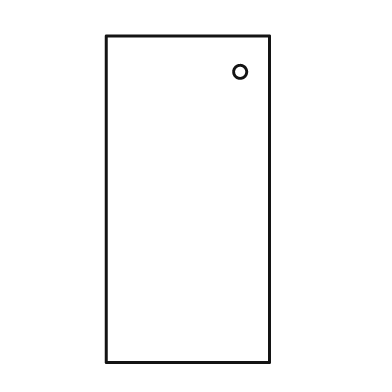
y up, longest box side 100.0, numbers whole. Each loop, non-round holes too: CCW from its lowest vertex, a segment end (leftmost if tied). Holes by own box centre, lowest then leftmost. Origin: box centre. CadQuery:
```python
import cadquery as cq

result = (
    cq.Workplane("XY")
    .moveTo(-25.0, -50.0)
    .lineTo(25.0, -50.0)
    .lineTo(25.0, 50.0)
    .lineTo(-25.0, 50.0)
    .close()
    .moveTo(16.0, 39.0)
    .circle(2.0)
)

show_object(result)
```